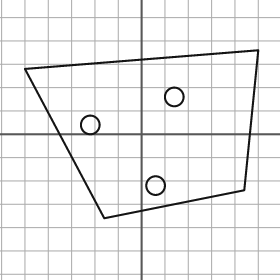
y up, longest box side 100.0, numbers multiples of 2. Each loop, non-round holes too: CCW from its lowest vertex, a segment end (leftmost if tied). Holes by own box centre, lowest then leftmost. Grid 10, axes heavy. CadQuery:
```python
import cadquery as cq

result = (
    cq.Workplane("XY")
    .moveTo(-16.0, -36.0)
    .lineTo(44.0, -24.0)
    .lineTo(50.0, 36.0)
    .lineTo(-50.0, 28.0)
    .close()
    .moveTo(6.0, -22.0)
    .circle(4.0)
    .moveTo(-22.0, 4.0)
    .circle(4.0)
    .moveTo(14.0, 16.0)
    .circle(4.0)
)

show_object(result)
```